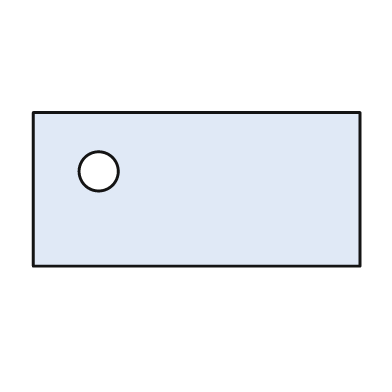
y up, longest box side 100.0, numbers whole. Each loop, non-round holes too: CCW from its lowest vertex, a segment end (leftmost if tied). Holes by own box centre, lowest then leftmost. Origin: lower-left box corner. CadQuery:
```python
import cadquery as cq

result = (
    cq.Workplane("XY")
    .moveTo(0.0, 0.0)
    .lineTo(100.0, 0.0)
    .lineTo(100.0, 47.0)
    .lineTo(0.0, 47.0)
    .close()
    .moveTo(20.0, 29.0)
    .circle(6.0)
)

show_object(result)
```